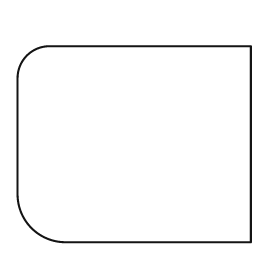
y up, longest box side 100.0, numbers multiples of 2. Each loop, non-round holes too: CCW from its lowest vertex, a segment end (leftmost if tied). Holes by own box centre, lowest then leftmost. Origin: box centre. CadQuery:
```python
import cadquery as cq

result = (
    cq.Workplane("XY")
    .moveTo(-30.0, -42.0)
    .lineTo(50.0, -42.0)
    .lineTo(50.0, 42.0)
    .lineTo(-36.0, 42.0)
    .threePointArc((-46.0, 38.0), (-50.0, 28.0))
    .lineTo(-50.0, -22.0)
    .threePointArc((-44.0, -36.0), (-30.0, -42.0))
    .close()
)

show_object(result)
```